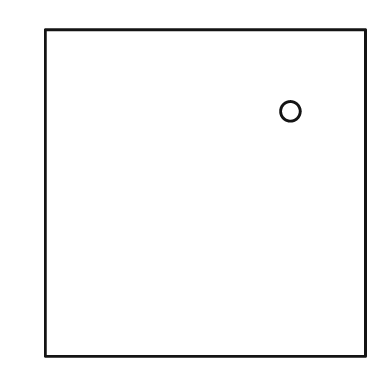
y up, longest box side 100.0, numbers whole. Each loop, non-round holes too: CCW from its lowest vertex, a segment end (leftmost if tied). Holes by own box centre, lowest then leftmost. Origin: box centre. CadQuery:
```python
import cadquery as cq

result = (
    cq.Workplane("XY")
    .moveTo(-49.0, -50.0)
    .lineTo(49.0, -50.0)
    .lineTo(49.0, 50.0)
    .lineTo(-49.0, 50.0)
    .close()
    .moveTo(26.0, 25.0)
    .circle(3.0)
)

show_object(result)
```